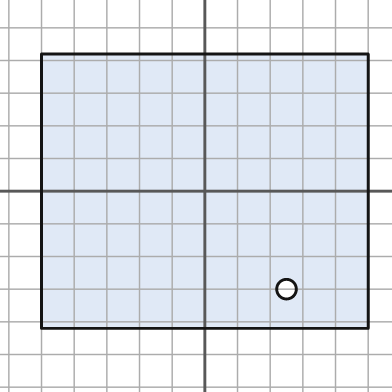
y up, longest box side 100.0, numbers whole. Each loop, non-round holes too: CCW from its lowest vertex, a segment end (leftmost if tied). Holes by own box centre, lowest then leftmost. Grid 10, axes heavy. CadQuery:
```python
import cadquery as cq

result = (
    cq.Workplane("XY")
    .moveTo(-50.0, -42.0)
    .lineTo(50.0, -42.0)
    .lineTo(50.0, 42.0)
    .lineTo(-50.0, 42.0)
    .close()
    .moveTo(25.0, -30.0)
    .circle(3.0)
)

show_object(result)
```